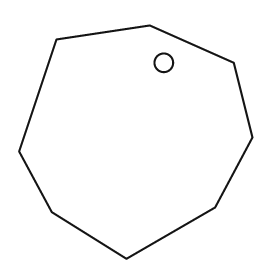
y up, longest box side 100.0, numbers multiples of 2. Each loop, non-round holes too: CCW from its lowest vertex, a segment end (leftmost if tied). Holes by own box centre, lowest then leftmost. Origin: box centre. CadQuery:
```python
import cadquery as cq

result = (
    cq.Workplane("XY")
    .moveTo(-4.0, -50.0)
    .lineTo(34.0, -28.0)
    .lineTo(50.0, 2.0)
    .lineTo(42.0, 34.0)
    .lineTo(6.0, 50.0)
    .lineTo(-34.0, 44.0)
    .lineTo(-50.0, -4.0)
    .lineTo(-36.0, -30.0)
    .close()
    .moveTo(12.0, 34.0)
    .circle(4.0)
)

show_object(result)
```